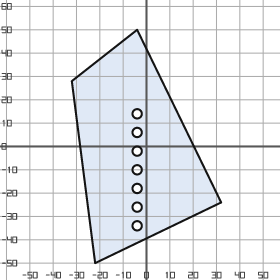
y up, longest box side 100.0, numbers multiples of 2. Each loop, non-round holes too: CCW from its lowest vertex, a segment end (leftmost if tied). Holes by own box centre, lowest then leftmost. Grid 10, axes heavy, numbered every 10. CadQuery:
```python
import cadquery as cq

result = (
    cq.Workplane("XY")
    .moveTo(-22.0, -50.0)
    .lineTo(32.0, -24.0)
    .lineTo(-4.0, 50.0)
    .lineTo(-32.0, 28.0)
    .close()
    .moveTo(-4.0, -34.0)
    .circle(2.0)
    .moveTo(-4.0, -26.0)
    .circle(2.0)
    .moveTo(-4.0, -18.0)
    .circle(2.0)
    .moveTo(-4.0, -10.0)
    .circle(2.0)
    .moveTo(-4.0, -2.0)
    .circle(2.0)
    .moveTo(-4.0, 6.0)
    .circle(2.0)
    .moveTo(-4.0, 14.0)
    .circle(2.0)
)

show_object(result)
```